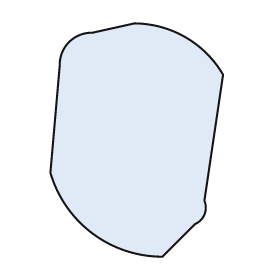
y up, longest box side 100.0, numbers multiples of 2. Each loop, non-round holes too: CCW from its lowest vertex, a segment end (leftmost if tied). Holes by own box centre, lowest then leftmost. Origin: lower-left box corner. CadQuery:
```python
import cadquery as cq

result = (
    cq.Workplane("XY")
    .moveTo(48.0, 0.0)
    .lineTo(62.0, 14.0)
    .threePointArc((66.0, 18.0), (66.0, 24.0))
    .lineTo(74.0, 78.0)
    .threePointArc((58.0, 94.0), (36.0, 100.0))
    .lineTo(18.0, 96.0)
    .threePointArc((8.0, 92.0), (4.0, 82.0))
    .lineTo(0.0, 36.0)
    .threePointArc((18.0, 10.0), (48.0, 0.0))
    .close()
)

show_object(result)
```